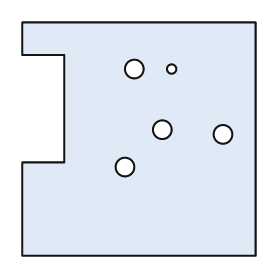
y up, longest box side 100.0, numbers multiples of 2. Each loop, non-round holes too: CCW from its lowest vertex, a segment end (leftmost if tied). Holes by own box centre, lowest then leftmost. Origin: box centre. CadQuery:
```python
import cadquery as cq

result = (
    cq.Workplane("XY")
    .moveTo(-50.0, -50.0)
    .lineTo(50.0, -50.0)
    .lineTo(50.0, 50.0)
    .lineTo(-50.0, 50.0)
    .lineTo(-50.0, 36.0)
    .lineTo(-32.0, 36.0)
    .lineTo(-32.0, -10.0)
    .lineTo(-50.0, -10.0)
    .close()
    .moveTo(-6.0, -12.0)
    .circle(4.0)
    .moveTo(36.0, 2.0)
    .circle(4.0)
    .moveTo(10.0, 4.0)
    .circle(4.0)
    .moveTo(-2.0, 30.0)
    .circle(4.0)
    .moveTo(14.0, 30.0)
    .circle(2.0)
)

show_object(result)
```